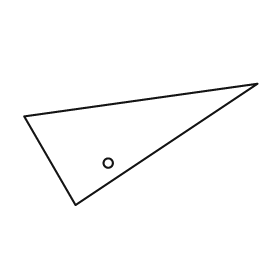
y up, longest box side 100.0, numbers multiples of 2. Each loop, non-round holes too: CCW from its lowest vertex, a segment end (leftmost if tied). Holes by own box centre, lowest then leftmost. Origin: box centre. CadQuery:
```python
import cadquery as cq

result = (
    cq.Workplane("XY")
    .moveTo(-28.0, -26.0)
    .lineTo(50.0, 26.0)
    .lineTo(-50.0, 12.0)
    .close()
    .moveTo(-14.0, -8.0)
    .circle(2.0)
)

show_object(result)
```